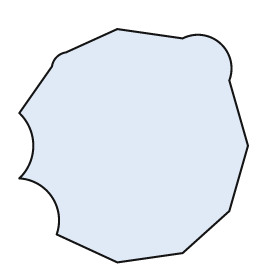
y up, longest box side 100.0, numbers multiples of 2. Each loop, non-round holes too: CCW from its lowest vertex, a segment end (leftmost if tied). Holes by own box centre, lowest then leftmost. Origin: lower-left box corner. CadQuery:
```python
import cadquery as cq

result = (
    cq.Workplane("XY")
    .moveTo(42.0, 0.0)
    .lineTo(70.0, 4.0)
    .lineTo(90.0, 22.0)
    .lineTo(98.0, 50.0)
    .lineTo(90.0, 78.0)
    .threePointArc((86.0, 94.0), (70.0, 96.0))
    .lineTo(42.0, 100.0)
    .lineTo(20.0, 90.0)
    .threePointArc((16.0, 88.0), (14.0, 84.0))
    .lineTo(0.0, 64.0)
    .threePointArc((6.0, 50.0), (0.0, 36.0))
    .threePointArc((14.0, 28.0), (16.0, 12.0))
    .close()
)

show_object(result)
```